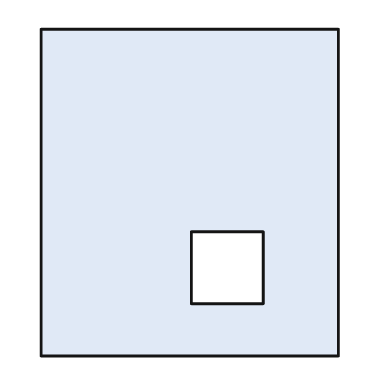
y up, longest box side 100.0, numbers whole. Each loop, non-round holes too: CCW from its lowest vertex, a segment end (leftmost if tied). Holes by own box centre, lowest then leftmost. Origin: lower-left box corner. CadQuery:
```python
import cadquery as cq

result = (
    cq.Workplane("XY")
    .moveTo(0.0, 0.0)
    .lineTo(91.0, 0.0)
    .lineTo(91.0, 100.0)
    .lineTo(0.0, 100.0)
    .close()
    .moveTo(46.0, 16.0)
    .lineTo(68.0, 16.0)
    .lineTo(68.0, 38.0)
    .lineTo(46.0, 38.0)
    .close()
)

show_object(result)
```